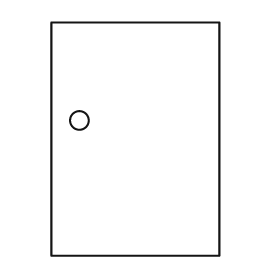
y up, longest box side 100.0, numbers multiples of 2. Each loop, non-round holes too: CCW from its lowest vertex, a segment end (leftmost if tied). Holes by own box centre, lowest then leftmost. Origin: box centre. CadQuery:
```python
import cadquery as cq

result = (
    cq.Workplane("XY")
    .moveTo(-36.0, -50.0)
    .lineTo(36.0, -50.0)
    .lineTo(36.0, 50.0)
    .lineTo(-36.0, 50.0)
    .close()
    .moveTo(-24.0, 8.0)
    .circle(4.0)
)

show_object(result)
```